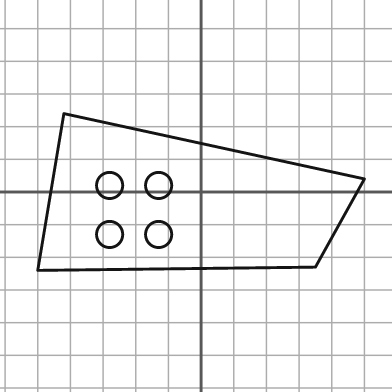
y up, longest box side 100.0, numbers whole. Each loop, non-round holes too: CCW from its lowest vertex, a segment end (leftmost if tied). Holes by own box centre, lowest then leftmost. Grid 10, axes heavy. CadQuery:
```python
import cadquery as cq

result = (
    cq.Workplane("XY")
    .moveTo(-50.0, -24.0)
    .lineTo(35.0, -23.0)
    .lineTo(50.0, 4.0)
    .lineTo(-42.0, 24.0)
    .close()
    .moveTo(-28.0, -13.0)
    .circle(4.0)
    .moveTo(-13.0, -13.0)
    .circle(4.0)
    .moveTo(-28.0, 2.0)
    .circle(4.0)
    .moveTo(-13.0, 2.0)
    .circle(4.0)
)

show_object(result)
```